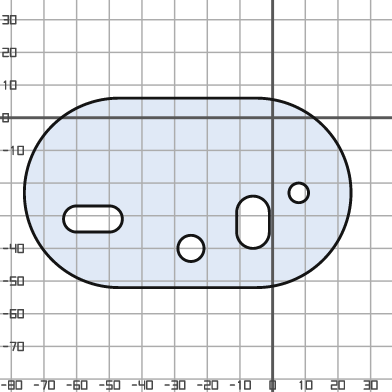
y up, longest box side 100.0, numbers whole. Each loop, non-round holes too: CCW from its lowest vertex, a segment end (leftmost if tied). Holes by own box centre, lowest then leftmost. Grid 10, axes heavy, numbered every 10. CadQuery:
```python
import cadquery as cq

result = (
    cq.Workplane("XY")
    .moveTo(-47.0, -52.0)
    .lineTo(-5.0, -52.0)
    .threePointArc((24.0, -23.0), (-5.0, 6.0))
    .lineTo(-47.0, 6.0)
    .threePointArc((-76.0, -23.0), (-47.0, -52.0))
    .close()
    .moveTo(-25.0, -40.0)
    .circle(4.0)
    .moveTo(-11.0, -35.0)
    .threePointArc((-6.0, -40.0), (-1.0, -35.0))
    .lineTo(-1.0, -29.0)
    .threePointArc((-6.0, -24.0), (-11.0, -29.0))
    .close()
    .moveTo(-60.0, -35.0)
    .lineTo(-50.0, -35.0)
    .threePointArc((-46.0, -31.0), (-50.0, -27.0))
    .lineTo(-60.0, -27.0)
    .threePointArc((-64.0, -31.0), (-60.0, -35.0))
    .close()
    .moveTo(8.0, -23.0)
    .circle(3.0)
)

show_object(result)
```